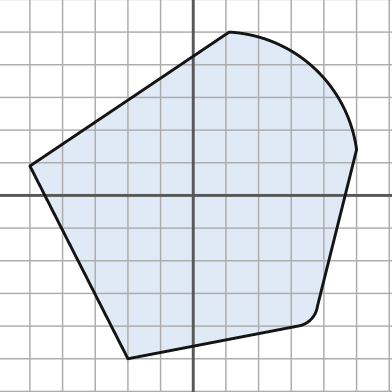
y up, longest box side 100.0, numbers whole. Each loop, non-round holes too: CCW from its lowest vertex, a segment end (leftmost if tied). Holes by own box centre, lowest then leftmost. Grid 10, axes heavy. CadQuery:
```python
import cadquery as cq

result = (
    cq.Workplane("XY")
    .moveTo(-20.0, -50.0)
    .lineTo(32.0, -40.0)
    .threePointArc((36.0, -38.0), (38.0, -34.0))
    .lineTo(50.0, 14.0)
    .threePointArc((37.0, 39.0), (11.0, 50.0))
    .lineTo(-50.0, 9.0)
    .close()
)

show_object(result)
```